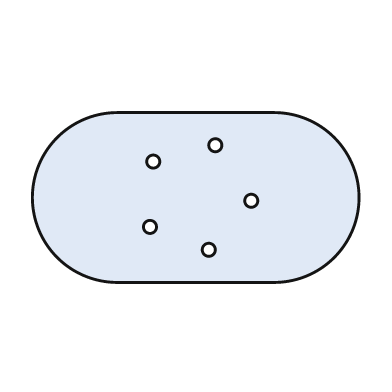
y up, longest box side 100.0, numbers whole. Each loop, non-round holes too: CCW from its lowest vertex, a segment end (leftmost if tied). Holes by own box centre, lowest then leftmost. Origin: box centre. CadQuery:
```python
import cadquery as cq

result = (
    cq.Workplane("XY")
    .moveTo(-24.0, -26.0)
    .lineTo(24.0, -26.0)
    .threePointArc((50.0, 0.0), (24.0, 26.0))
    .lineTo(-24.0, 26.0)
    .threePointArc((-50.0, 0.0), (-24.0, -26.0))
    .close()
    .moveTo(4.0, -16.0)
    .circle(2.0)
    .moveTo(-14.0, -9.0)
    .circle(2.0)
    .moveTo(17.0, -1.0)
    .circle(2.0)
    .moveTo(-13.0, 11.0)
    .circle(2.0)
    .moveTo(6.0, 16.0)
    .circle(2.0)
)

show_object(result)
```